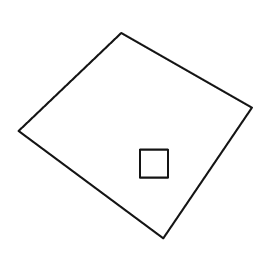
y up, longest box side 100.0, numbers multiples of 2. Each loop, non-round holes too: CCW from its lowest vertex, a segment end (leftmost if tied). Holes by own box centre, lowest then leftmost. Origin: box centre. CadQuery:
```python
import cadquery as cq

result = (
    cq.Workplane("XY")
    .moveTo(12.0, -44.0)
    .lineTo(50.0, 12.0)
    .lineTo(-6.0, 44.0)
    .lineTo(-50.0, 2.0)
    .close()
    .moveTo(2.0, -18.0)
    .lineTo(14.0, -18.0)
    .lineTo(14.0, -6.0)
    .lineTo(2.0, -6.0)
    .close()
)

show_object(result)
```